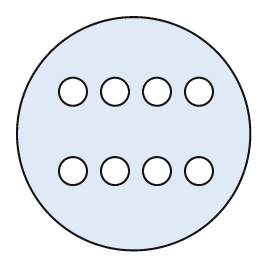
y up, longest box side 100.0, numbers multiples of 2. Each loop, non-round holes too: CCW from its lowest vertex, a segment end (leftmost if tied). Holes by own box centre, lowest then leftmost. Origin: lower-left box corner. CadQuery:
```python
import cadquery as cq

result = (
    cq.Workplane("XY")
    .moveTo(50.0, 50.0)
    .circle(50.0)
    .moveTo(24.0, 34.0)
    .circle(6.0)
    .moveTo(42.0, 34.0)
    .circle(6.0)
    .moveTo(60.0, 34.0)
    .circle(6.0)
    .moveTo(78.0, 34.0)
    .circle(6.0)
    .moveTo(24.0, 68.0)
    .circle(6.0)
    .moveTo(42.0, 68.0)
    .circle(6.0)
    .moveTo(60.0, 68.0)
    .circle(6.0)
    .moveTo(78.0, 68.0)
    .circle(6.0)
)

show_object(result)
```